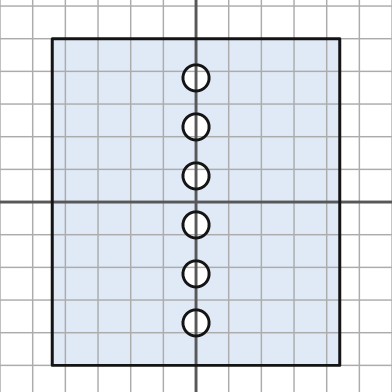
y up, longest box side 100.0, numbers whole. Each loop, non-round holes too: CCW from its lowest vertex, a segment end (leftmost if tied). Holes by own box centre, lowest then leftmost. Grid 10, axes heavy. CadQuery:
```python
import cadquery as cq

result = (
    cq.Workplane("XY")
    .moveTo(-44.0, -50.0)
    .lineTo(44.0, -50.0)
    .lineTo(44.0, 50.0)
    .lineTo(-44.0, 50.0)
    .close()
    .moveTo(0.0, -37.0)
    .circle(4.0)
    .moveTo(0.0, -22.0)
    .circle(4.0)
    .moveTo(0.0, -7.0)
    .circle(4.0)
    .moveTo(0.0, 8.0)
    .circle(4.0)
    .moveTo(0.0, 23.0)
    .circle(4.0)
    .moveTo(0.0, 38.0)
    .circle(4.0)
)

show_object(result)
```